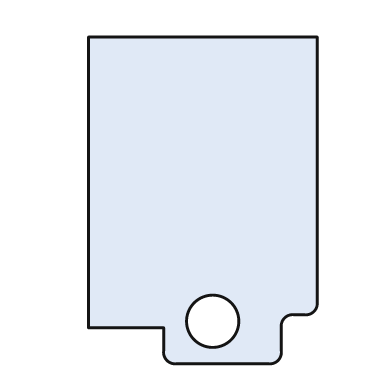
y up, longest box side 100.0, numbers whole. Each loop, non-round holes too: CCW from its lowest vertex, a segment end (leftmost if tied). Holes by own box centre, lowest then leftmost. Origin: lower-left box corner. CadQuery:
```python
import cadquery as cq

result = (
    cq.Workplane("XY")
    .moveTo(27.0, 0.0)
    .lineTo(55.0, 0.0)
    .threePointArc((58.0, 1.0), (59.0, 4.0))
    .lineTo(59.0, 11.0)
    .threePointArc((60.0, 14.0), (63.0, 15.0))
    .lineTo(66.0, 15.0)
    .threePointArc((69.0, 16.0), (70.0, 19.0))
    .lineTo(70.0, 100.0)
    .lineTo(0.0, 100.0)
    .lineTo(0.0, 11.0)
    .lineTo(23.0, 11.0)
    .lineTo(23.0, 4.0)
    .threePointArc((24.0, 1.0), (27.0, 0.0))
    .close()
    .moveTo(38.0, 13.0)
    .circle(8.0)
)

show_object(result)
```